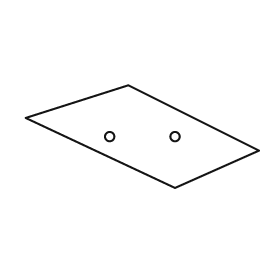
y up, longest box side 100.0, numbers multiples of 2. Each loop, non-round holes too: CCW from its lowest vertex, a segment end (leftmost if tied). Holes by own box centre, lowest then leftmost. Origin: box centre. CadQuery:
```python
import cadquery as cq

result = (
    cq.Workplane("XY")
    .moveTo(14.0, -22.0)
    .lineTo(50.0, -6.0)
    .lineTo(-6.0, 22.0)
    .lineTo(-50.0, 8.0)
    .close()
    .moveTo(-14.0, 0.0)
    .circle(2.0)
    .moveTo(14.0, 0.0)
    .circle(2.0)
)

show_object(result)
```